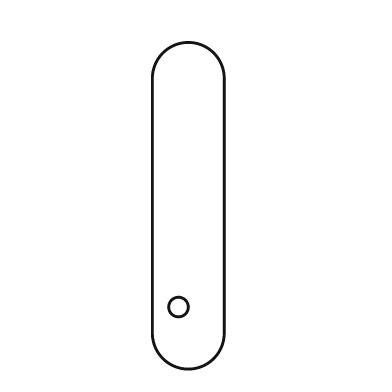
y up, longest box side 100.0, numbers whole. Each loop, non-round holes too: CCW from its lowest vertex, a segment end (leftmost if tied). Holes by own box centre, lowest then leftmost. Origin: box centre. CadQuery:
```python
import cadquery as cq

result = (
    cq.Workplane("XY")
    .moveTo(-11.0, -39.0)
    .threePointArc((0.0, -50.0), (11.0, -39.0))
    .lineTo(11.0, 39.0)
    .threePointArc((0.0, 50.0), (-11.0, 39.0))
    .close()
    .moveTo(-3.0, -31.0)
    .circle(3.0)
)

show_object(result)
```